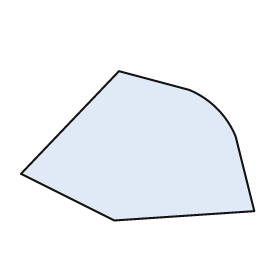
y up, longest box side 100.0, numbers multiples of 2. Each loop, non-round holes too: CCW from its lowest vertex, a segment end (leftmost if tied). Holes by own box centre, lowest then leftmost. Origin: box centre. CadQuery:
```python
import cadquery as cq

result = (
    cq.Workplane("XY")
    .moveTo(-10.0, -32.0)
    .lineTo(50.0, -28.0)
    .lineTo(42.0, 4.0)
    .threePointArc((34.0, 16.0), (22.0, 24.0))
    .lineTo(-8.0, 32.0)
    .lineTo(-50.0, -12.0)
    .close()
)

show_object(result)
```